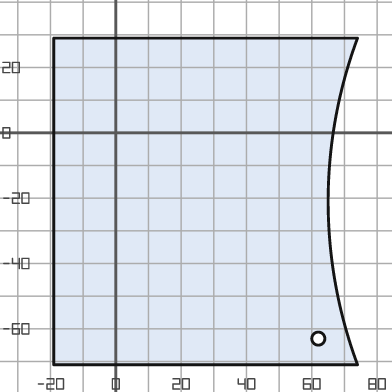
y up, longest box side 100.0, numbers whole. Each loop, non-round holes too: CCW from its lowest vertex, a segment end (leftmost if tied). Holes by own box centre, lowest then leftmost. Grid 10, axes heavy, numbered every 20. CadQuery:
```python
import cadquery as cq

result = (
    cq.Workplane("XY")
    .moveTo(-19.0, -71.0)
    .lineTo(74.0, -71.0)
    .threePointArc((65.0, -21.0), (74.0, 29.0))
    .lineTo(-19.0, 29.0)
    .close()
    .moveTo(62.0, -63.0)
    .circle(2.0)
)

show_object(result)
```